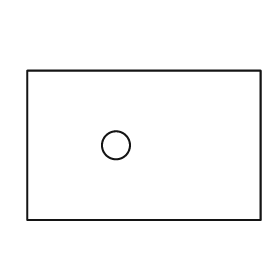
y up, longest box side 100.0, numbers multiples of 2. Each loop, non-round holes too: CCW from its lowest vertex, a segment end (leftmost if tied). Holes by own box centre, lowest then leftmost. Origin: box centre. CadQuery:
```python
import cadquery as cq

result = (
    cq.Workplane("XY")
    .moveTo(-50.0, -32.0)
    .lineTo(50.0, -32.0)
    .lineTo(50.0, 32.0)
    .lineTo(-50.0, 32.0)
    .close()
    .moveTo(-12.0, 0.0)
    .circle(6.0)
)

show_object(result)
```